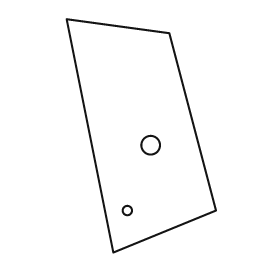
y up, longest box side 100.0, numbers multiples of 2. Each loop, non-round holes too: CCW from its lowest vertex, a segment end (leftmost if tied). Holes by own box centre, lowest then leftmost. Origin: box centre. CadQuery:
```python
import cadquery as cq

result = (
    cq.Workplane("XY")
    .moveTo(-12.0, -50.0)
    .lineTo(32.0, -32.0)
    .lineTo(12.0, 44.0)
    .lineTo(-32.0, 50.0)
    .close()
    .moveTo(-6.0, -32.0)
    .circle(2.0)
    .moveTo(4.0, -4.0)
    .circle(4.0)
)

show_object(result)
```